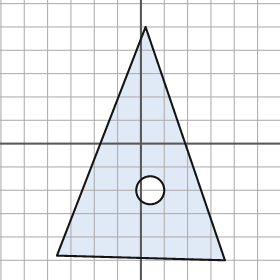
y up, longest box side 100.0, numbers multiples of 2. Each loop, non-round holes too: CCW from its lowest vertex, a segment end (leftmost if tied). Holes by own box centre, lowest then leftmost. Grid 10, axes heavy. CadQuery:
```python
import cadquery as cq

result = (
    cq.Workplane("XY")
    .moveTo(36.0, -50.0)
    .lineTo(2.0, 50.0)
    .lineTo(-36.0, -48.0)
    .close()
    .moveTo(4.0, -20.0)
    .circle(6.0)
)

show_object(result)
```